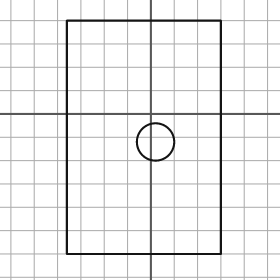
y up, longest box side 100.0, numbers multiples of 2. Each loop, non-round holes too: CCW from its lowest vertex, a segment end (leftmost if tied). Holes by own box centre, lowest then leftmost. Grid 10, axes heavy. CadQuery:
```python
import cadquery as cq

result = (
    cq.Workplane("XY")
    .moveTo(-36.0, -60.0)
    .lineTo(30.0, -60.0)
    .lineTo(30.0, 40.0)
    .lineTo(-36.0, 40.0)
    .close()
    .moveTo(2.0, -12.0)
    .circle(8.0)
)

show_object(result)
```